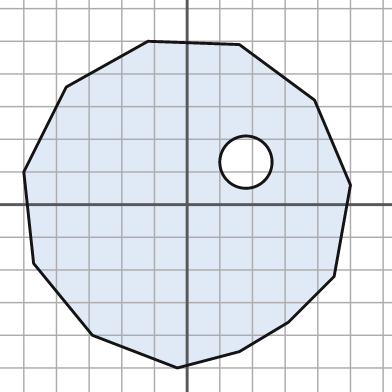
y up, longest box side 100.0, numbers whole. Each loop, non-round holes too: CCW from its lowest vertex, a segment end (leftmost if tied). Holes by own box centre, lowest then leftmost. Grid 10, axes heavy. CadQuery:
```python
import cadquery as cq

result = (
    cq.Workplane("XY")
    .moveTo(-3.0, -50.0)
    .lineTo(16.0, -45.0)
    .lineTo(31.0, -36.0)
    .lineTo(45.0, -22.0)
    .lineTo(50.0, 6.0)
    .lineTo(39.0, 32.0)
    .lineTo(16.0, 49.0)
    .lineTo(-12.0, 50.0)
    .lineTo(-37.0, 36.0)
    .lineTo(-50.0, 10.0)
    .lineTo(-47.0, -18.0)
    .lineTo(-29.0, -40.0)
    .close()
    .moveTo(18.0, 13.0)
    .circle(8.0)
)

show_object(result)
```